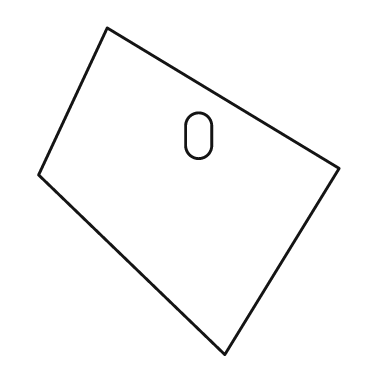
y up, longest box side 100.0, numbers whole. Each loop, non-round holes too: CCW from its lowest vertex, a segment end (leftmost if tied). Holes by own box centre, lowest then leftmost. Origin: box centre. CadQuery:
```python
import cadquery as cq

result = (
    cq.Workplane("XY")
    .moveTo(11.0, -50.0)
    .lineTo(46.0, 7.0)
    .lineTo(-25.0, 50.0)
    .lineTo(-46.0, 5.0)
    .close()
    .moveTo(-1.0, 14.0)
    .threePointArc((3.0, 10.0), (7.0, 14.0))
    .lineTo(7.0, 20.0)
    .threePointArc((3.0, 24.0), (-1.0, 20.0))
    .close()
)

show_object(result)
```